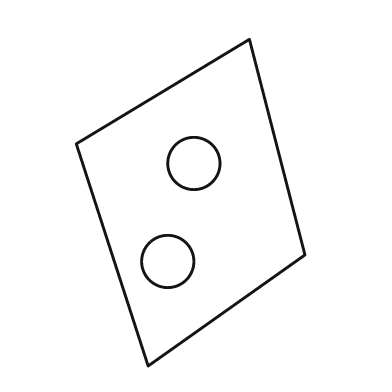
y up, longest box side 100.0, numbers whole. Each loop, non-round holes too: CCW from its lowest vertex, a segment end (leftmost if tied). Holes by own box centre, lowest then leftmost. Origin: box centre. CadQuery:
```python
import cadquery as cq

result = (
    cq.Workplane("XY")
    .moveTo(-13.0, -50.0)
    .lineTo(35.0, -16.0)
    .lineTo(18.0, 50.0)
    .lineTo(-35.0, 18.0)
    .close()
    .moveTo(-7.0, -18.0)
    .circle(8.0)
    .moveTo(1.0, 12.0)
    .circle(8.0)
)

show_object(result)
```